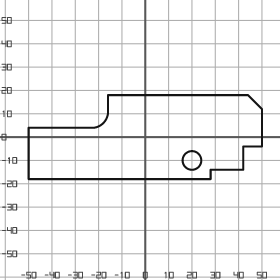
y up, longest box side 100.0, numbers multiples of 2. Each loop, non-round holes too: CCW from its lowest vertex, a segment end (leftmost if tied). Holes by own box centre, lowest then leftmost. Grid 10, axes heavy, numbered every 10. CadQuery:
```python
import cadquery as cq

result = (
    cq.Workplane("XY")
    .moveTo(-50.0, -18.0)
    .lineTo(28.0, -18.0)
    .lineTo(28.0, -14.0)
    .lineTo(42.0, -14.0)
    .lineTo(42.0, -4.0)
    .lineTo(50.0, -4.0)
    .lineTo(50.0, 12.0)
    .lineTo(44.0, 18.0)
    .lineTo(-16.0, 18.0)
    .lineTo(-16.0, 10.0)
    .threePointArc((-18.0, 6.0), (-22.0, 4.0))
    .lineTo(-50.0, 4.0)
    .close()
    .moveTo(20.0, -10.0)
    .circle(4.0)
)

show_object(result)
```